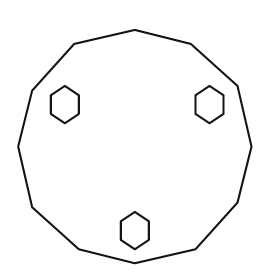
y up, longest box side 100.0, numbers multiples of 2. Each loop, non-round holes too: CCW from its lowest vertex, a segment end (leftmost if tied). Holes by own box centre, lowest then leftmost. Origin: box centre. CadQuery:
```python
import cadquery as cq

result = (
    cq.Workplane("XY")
    .moveTo(0.0, -50.0)
    .lineTo(26.0, -44.0)
    .lineTo(44.0, -24.0)
    .lineTo(50.0, 0.0)
    .lineTo(44.0, 26.0)
    .lineTo(24.0, 44.0)
    .lineTo(0.0, 50.0)
    .lineTo(-26.0, 44.0)
    .lineTo(-44.0, 24.0)
    .lineTo(-50.0, 0.0)
    .lineTo(-44.0, -26.0)
    .lineTo(-24.0, -44.0)
    .close()
    .moveTo(0.0, -44.0)
    .lineTo(6.0, -40.0)
    .lineTo(6.0, -32.0)
    .lineTo(0.0, -28.0)
    .lineTo(-6.0, -32.0)
    .lineTo(-6.0, -40.0)
    .close()
    .moveTo(-30.0, 10.0)
    .lineTo(-24.0, 14.0)
    .lineTo(-24.0, 22.0)
    .lineTo(-30.0, 26.0)
    .lineTo(-36.0, 22.0)
    .lineTo(-36.0, 14.0)
    .close()
    .moveTo(32.0, 10.0)
    .lineTo(38.0, 14.0)
    .lineTo(38.0, 22.0)
    .lineTo(32.0, 26.0)
    .lineTo(26.0, 22.0)
    .lineTo(26.0, 14.0)
    .close()
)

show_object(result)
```